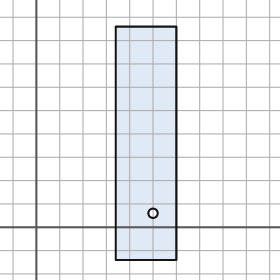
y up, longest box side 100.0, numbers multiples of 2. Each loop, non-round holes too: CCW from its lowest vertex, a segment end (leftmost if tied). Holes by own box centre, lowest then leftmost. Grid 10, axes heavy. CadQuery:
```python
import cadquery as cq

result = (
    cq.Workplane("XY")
    .moveTo(34.0, -14.0)
    .lineTo(60.0, -14.0)
    .lineTo(60.0, 86.0)
    .lineTo(34.0, 86.0)
    .close()
    .moveTo(50.0, 6.0)
    .circle(2.0)
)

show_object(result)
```